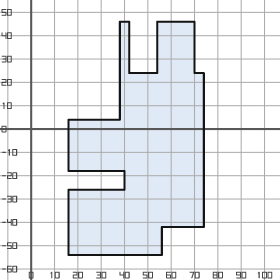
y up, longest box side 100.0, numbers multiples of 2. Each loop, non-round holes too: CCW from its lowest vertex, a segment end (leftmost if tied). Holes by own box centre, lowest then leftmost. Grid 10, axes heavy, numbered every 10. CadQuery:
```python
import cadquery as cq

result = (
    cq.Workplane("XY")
    .moveTo(16.0, -54.0)
    .lineTo(56.0, -54.0)
    .lineTo(56.0, -42.0)
    .lineTo(74.0, -42.0)
    .lineTo(74.0, 24.0)
    .lineTo(70.0, 24.0)
    .lineTo(70.0, 46.0)
    .lineTo(54.0, 46.0)
    .lineTo(54.0, 24.0)
    .lineTo(42.0, 24.0)
    .lineTo(42.0, 46.0)
    .lineTo(38.0, 46.0)
    .lineTo(38.0, 4.0)
    .lineTo(16.0, 4.0)
    .lineTo(16.0, -18.0)
    .lineTo(40.0, -18.0)
    .lineTo(40.0, -26.0)
    .lineTo(16.0, -26.0)
    .close()
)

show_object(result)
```